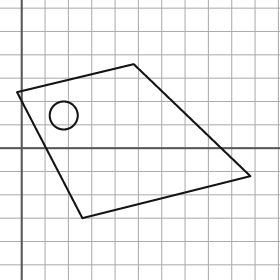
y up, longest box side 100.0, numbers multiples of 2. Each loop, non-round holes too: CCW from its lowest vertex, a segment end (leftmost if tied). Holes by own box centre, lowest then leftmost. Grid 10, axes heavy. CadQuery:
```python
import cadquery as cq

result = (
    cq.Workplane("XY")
    .moveTo(26.0, -30.0)
    .lineTo(98.0, -12.0)
    .lineTo(48.0, 36.0)
    .lineTo(-2.0, 24.0)
    .close()
    .moveTo(18.0, 14.0)
    .circle(6.0)
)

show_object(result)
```